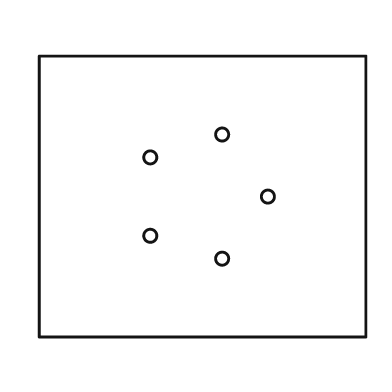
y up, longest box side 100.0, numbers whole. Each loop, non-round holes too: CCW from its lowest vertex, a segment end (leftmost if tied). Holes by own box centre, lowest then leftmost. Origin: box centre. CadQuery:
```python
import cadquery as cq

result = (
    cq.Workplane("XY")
    .moveTo(-50.0, -43.0)
    .lineTo(50.0, -43.0)
    .lineTo(50.0, 43.0)
    .lineTo(-50.0, 43.0)
    .close()
    .moveTo(6.0, -19.0)
    .circle(2.0)
    .moveTo(-16.0, -12.0)
    .circle(2.0)
    .moveTo(20.0, 0.0)
    .circle(2.0)
    .moveTo(-16.0, 12.0)
    .circle(2.0)
    .moveTo(6.0, 19.0)
    .circle(2.0)
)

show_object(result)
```